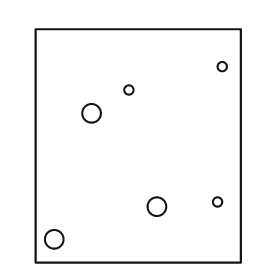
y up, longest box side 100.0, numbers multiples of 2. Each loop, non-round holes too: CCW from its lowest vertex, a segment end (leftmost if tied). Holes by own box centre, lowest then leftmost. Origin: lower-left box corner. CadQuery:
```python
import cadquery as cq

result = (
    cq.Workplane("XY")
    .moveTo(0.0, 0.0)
    .lineTo(88.0, 0.0)
    .lineTo(88.0, 100.0)
    .lineTo(0.0, 100.0)
    .close()
    .moveTo(8.0, 10.0)
    .circle(4.0)
    .moveTo(52.0, 24.0)
    .circle(4.0)
    .moveTo(78.0, 26.0)
    .circle(2.0)
    .moveTo(24.0, 64.0)
    .circle(4.0)
    .moveTo(40.0, 74.0)
    .circle(2.0)
    .moveTo(80.0, 84.0)
    .circle(2.0)
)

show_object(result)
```